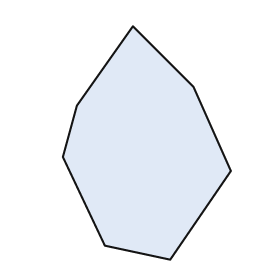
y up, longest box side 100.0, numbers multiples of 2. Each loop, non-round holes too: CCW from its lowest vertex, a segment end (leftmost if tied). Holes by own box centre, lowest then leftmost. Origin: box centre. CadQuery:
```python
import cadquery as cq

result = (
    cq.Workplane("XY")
    .moveTo(10.0, -50.0)
    .lineTo(36.0, -12.0)
    .lineTo(20.0, 24.0)
    .lineTo(-6.0, 50.0)
    .lineTo(-30.0, 16.0)
    .lineTo(-36.0, -6.0)
    .lineTo(-18.0, -44.0)
    .close()
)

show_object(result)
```